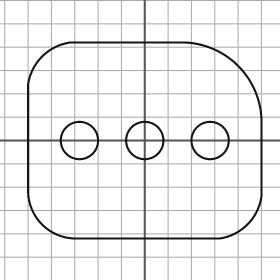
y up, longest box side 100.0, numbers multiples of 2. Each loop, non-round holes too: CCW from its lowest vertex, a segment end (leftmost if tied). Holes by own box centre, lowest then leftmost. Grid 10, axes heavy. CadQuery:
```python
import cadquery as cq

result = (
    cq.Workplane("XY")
    .moveTo(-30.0, -42.0)
    .lineTo(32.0, -42.0)
    .threePointArc((44.0, -36.0), (50.0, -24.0))
    .lineTo(50.0, 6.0)
    .threePointArc((40.0, 32.0), (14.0, 42.0))
    .lineTo(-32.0, 42.0)
    .threePointArc((-44.0, 36.0), (-50.0, 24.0))
    .lineTo(-50.0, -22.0)
    .threePointArc((-44.0, -36.0), (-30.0, -42.0))
    .close()
    .moveTo(-28.0, 0.0)
    .circle(8.0)
    .moveTo(0.0, 0.0)
    .circle(8.0)
    .moveTo(28.0, 0.0)
    .circle(8.0)
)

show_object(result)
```